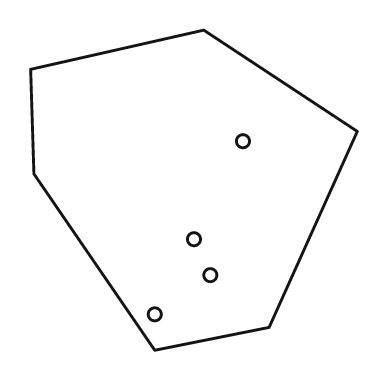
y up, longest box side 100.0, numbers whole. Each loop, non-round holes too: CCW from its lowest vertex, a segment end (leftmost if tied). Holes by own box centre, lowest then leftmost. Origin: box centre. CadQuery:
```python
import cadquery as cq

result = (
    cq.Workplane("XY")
    .moveTo(-12.0, -49.0)
    .lineTo(23.0, -42.0)
    .lineTo(50.0, 18.0)
    .lineTo(3.0, 49.0)
    .lineTo(-50.0, 37.0)
    .lineTo(-49.0, 5.0)
    .close()
    .moveTo(-12.0, -38.0)
    .circle(2.0)
    .moveTo(5.0, -26.0)
    .circle(2.0)
    .moveTo(0.0, -15.0)
    .circle(2.0)
    .moveTo(15.0, 15.0)
    .circle(2.0)
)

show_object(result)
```